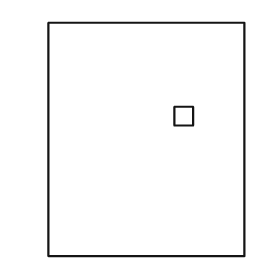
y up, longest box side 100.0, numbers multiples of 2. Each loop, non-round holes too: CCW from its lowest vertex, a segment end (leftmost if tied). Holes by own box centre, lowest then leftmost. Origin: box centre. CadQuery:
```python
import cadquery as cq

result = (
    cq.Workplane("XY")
    .moveTo(-42.0, -50.0)
    .lineTo(42.0, -50.0)
    .lineTo(42.0, 50.0)
    .lineTo(-42.0, 50.0)
    .close()
    .moveTo(12.0, 6.0)
    .lineTo(20.0, 6.0)
    .lineTo(20.0, 14.0)
    .lineTo(12.0, 14.0)
    .close()
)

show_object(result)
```